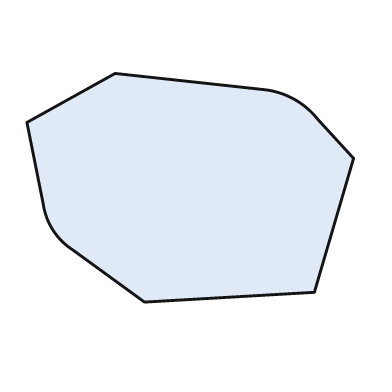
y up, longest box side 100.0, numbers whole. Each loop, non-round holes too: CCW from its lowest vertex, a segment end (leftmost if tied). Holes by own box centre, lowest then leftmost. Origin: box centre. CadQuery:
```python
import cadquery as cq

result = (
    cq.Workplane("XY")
    .moveTo(-14.0, -35.0)
    .lineTo(38.0, -32.0)
    .lineTo(50.0, 9.0)
    .lineTo(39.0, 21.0)
    .threePointArc((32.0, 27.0), (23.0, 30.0))
    .lineTo(-23.0, 35.0)
    .lineTo(-50.0, 20.0)
    .lineTo(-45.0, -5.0)
    .threePointArc((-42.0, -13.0), (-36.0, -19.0))
    .close()
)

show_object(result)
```